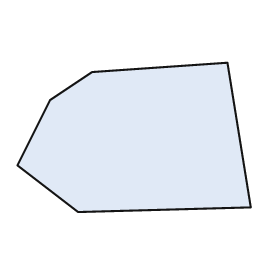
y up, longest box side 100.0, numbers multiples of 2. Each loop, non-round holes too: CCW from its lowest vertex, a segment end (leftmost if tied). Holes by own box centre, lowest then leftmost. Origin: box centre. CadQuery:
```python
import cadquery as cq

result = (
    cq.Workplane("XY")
    .moveTo(-24.0, -32.0)
    .lineTo(50.0, -30.0)
    .lineTo(40.0, 32.0)
    .lineTo(-18.0, 28.0)
    .lineTo(-36.0, 16.0)
    .lineTo(-50.0, -12.0)
    .close()
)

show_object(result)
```